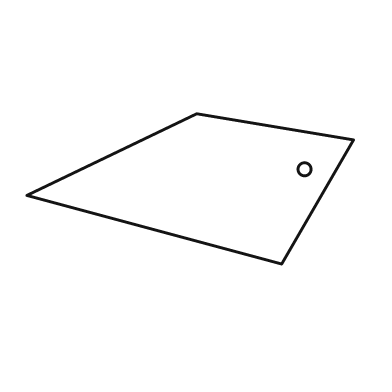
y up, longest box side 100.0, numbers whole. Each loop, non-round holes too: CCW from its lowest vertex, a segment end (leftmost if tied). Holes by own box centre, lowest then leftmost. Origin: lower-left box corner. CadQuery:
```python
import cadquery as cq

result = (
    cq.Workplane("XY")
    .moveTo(78.0, 0.0)
    .lineTo(100.0, 38.0)
    .lineTo(52.0, 46.0)
    .lineTo(0.0, 21.0)
    .close()
    .moveTo(85.0, 29.0)
    .circle(2.0)
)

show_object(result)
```